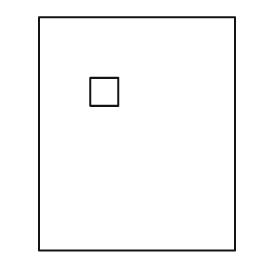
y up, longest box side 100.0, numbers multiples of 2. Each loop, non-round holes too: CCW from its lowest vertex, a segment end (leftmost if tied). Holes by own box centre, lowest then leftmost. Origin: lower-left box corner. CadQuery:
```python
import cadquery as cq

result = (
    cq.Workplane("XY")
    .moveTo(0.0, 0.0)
    .lineTo(84.0, 0.0)
    .lineTo(84.0, 100.0)
    .lineTo(0.0, 100.0)
    .close()
    .moveTo(22.0, 62.0)
    .lineTo(34.0, 62.0)
    .lineTo(34.0, 74.0)
    .lineTo(22.0, 74.0)
    .close()
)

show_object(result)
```